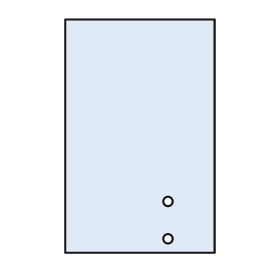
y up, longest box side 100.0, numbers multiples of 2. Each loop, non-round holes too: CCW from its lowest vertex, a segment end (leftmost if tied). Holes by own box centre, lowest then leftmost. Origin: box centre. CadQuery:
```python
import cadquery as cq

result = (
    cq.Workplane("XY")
    .moveTo(-32.0, -50.0)
    .lineTo(32.0, -50.0)
    .lineTo(32.0, 50.0)
    .lineTo(-32.0, 50.0)
    .close()
    .moveTo(12.0, -44.0)
    .circle(2.0)
    .moveTo(12.0, -28.0)
    .circle(2.0)
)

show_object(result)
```